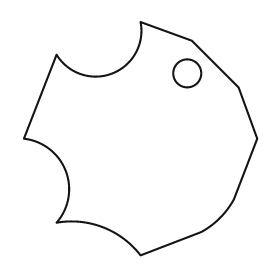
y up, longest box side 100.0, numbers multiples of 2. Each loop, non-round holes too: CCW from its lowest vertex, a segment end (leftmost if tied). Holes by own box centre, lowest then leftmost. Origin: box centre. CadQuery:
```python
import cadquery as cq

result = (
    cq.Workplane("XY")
    .moveTo(0.0, -50.0)
    .lineTo(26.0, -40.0)
    .threePointArc((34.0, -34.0), (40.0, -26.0))
    .lineTo(50.0, 0.0)
    .lineTo(42.0, 22.0)
    .lineTo(22.0, 42.0)
    .lineTo(0.0, 50.0)
    .threePointArc((-12.0, 28.0), (-36.0, 36.0))
    .lineTo(-50.0, 0.0)
    .threePointArc((-32.0, -14.0), (-36.0, -36.0))
    .threePointArc((-16.0, -38.0), (0.0, -50.0))
    .close()
    .moveTo(20.0, 28.0)
    .circle(6.0)
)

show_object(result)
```